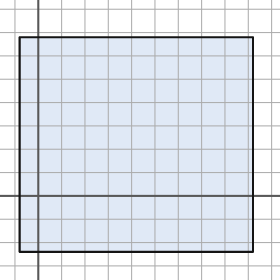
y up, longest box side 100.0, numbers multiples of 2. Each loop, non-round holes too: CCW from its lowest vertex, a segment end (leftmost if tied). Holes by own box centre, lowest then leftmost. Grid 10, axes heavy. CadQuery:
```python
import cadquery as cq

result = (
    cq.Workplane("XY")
    .moveTo(-8.0, -24.0)
    .lineTo(92.0, -24.0)
    .lineTo(92.0, 68.0)
    .lineTo(-8.0, 68.0)
    .close()
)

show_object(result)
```